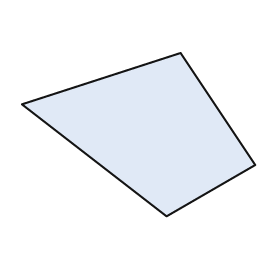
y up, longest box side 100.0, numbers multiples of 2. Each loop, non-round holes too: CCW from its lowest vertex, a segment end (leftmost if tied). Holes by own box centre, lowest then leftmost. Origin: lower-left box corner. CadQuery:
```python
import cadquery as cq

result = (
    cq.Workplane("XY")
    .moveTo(62.0, 0.0)
    .lineTo(100.0, 22.0)
    .lineTo(68.0, 70.0)
    .lineTo(0.0, 48.0)
    .close()
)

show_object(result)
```